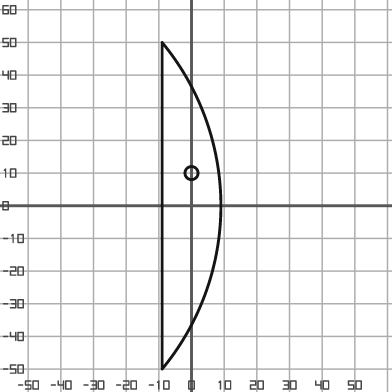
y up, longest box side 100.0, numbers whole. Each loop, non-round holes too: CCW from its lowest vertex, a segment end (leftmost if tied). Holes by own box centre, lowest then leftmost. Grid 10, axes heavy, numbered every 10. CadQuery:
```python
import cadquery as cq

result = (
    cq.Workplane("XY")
    .moveTo(-9.0, -50.0)
    .threePointArc((9.0, 0.0), (-9.0, 50.0))
    .close()
    .moveTo(0.0, 10.0)
    .circle(2.0)
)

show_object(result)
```